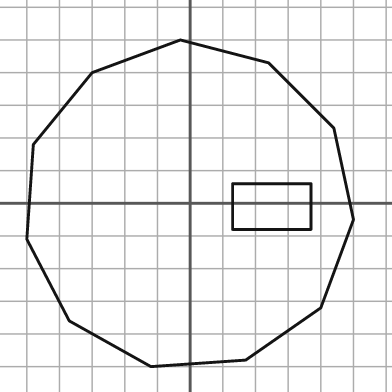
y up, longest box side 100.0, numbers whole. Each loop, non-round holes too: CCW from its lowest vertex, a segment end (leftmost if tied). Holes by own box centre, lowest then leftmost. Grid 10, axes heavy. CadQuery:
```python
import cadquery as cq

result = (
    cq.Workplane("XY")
    .moveTo(-12.0, -50.0)
    .lineTo(17.0, -48.0)
    .lineTo(40.0, -32.0)
    .lineTo(50.0, -5.0)
    .lineTo(44.0, 23.0)
    .lineTo(24.0, 43.0)
    .lineTo(-3.0, 50.0)
    .lineTo(-30.0, 40.0)
    .lineTo(-48.0, 18.0)
    .lineTo(-50.0, -11.0)
    .lineTo(-37.0, -36.0)
    .close()
    .moveTo(13.0, -8.0)
    .lineTo(37.0, -8.0)
    .lineTo(37.0, 6.0)
    .lineTo(13.0, 6.0)
    .close()
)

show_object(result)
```